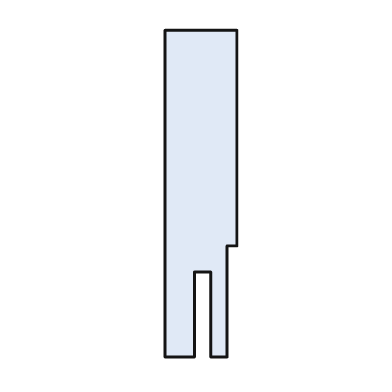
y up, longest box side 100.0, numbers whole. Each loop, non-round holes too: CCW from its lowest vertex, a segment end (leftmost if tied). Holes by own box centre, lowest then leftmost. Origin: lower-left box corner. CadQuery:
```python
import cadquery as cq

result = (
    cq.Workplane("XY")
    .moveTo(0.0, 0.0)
    .lineTo(9.0, 0.0)
    .lineTo(9.0, 26.0)
    .lineTo(14.0, 26.0)
    .lineTo(14.0, 0.0)
    .lineTo(19.0, 0.0)
    .lineTo(19.0, 34.0)
    .lineTo(22.0, 34.0)
    .lineTo(22.0, 100.0)
    .lineTo(0.0, 100.0)
    .close()
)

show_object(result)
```